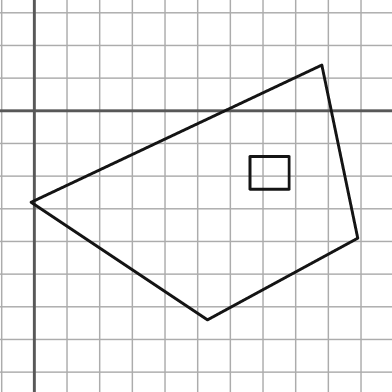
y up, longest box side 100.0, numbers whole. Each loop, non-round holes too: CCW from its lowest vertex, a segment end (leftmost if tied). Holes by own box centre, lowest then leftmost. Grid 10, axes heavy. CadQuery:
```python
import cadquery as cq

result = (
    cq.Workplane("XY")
    .moveTo(53.0, -64.0)
    .lineTo(99.0, -39.0)
    .lineTo(88.0, 14.0)
    .lineTo(-1.0, -28.0)
    .close()
    .moveTo(66.0, -24.0)
    .lineTo(78.0, -24.0)
    .lineTo(78.0, -14.0)
    .lineTo(66.0, -14.0)
    .close()
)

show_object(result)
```